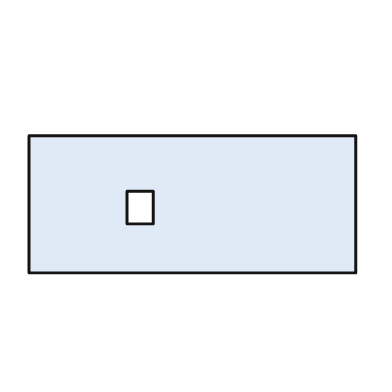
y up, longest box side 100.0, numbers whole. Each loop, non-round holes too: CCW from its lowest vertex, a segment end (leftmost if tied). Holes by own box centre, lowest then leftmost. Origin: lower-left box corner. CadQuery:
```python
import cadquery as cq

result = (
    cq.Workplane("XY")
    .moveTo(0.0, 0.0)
    .lineTo(100.0, 0.0)
    .lineTo(100.0, 42.0)
    .lineTo(0.0, 42.0)
    .close()
    .moveTo(30.0, 15.0)
    .lineTo(38.0, 15.0)
    .lineTo(38.0, 25.0)
    .lineTo(30.0, 25.0)
    .close()
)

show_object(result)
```